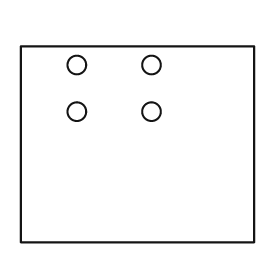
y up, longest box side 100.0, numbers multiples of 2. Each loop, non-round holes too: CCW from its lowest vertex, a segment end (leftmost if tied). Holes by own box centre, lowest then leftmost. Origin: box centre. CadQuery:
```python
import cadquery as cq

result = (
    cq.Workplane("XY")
    .moveTo(-50.0, -42.0)
    .lineTo(50.0, -42.0)
    .lineTo(50.0, 42.0)
    .lineTo(-50.0, 42.0)
    .close()
    .moveTo(-26.0, 14.0)
    .circle(4.0)
    .moveTo(6.0, 14.0)
    .circle(4.0)
    .moveTo(-26.0, 34.0)
    .circle(4.0)
    .moveTo(6.0, 34.0)
    .circle(4.0)
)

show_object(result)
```